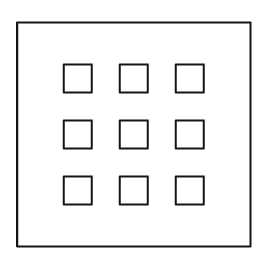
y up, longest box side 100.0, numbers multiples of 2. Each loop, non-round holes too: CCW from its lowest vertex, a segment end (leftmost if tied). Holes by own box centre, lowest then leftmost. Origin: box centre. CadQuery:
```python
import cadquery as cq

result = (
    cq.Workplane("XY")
    .moveTo(-50.0, -48.0)
    .lineTo(50.0, -48.0)
    .lineTo(50.0, 48.0)
    .lineTo(-50.0, 48.0)
    .close()
    .moveTo(-30.0, -30.0)
    .lineTo(-18.0, -30.0)
    .lineTo(-18.0, -18.0)
    .lineTo(-30.0, -18.0)
    .close()
    .moveTo(-6.0, -30.0)
    .lineTo(6.0, -30.0)
    .lineTo(6.0, -18.0)
    .lineTo(-6.0, -18.0)
    .close()
    .moveTo(18.0, -30.0)
    .lineTo(30.0, -30.0)
    .lineTo(30.0, -18.0)
    .lineTo(18.0, -18.0)
    .close()
    .moveTo(-30.0, -6.0)
    .lineTo(-18.0, -6.0)
    .lineTo(-18.0, 6.0)
    .lineTo(-30.0, 6.0)
    .close()
    .moveTo(-6.0, -6.0)
    .lineTo(6.0, -6.0)
    .lineTo(6.0, 6.0)
    .lineTo(-6.0, 6.0)
    .close()
    .moveTo(18.0, -6.0)
    .lineTo(30.0, -6.0)
    .lineTo(30.0, 6.0)
    .lineTo(18.0, 6.0)
    .close()
    .moveTo(-30.0, 18.0)
    .lineTo(-18.0, 18.0)
    .lineTo(-18.0, 30.0)
    .lineTo(-30.0, 30.0)
    .close()
    .moveTo(-6.0, 18.0)
    .lineTo(6.0, 18.0)
    .lineTo(6.0, 30.0)
    .lineTo(-6.0, 30.0)
    .close()
    .moveTo(18.0, 18.0)
    .lineTo(30.0, 18.0)
    .lineTo(30.0, 30.0)
    .lineTo(18.0, 30.0)
    .close()
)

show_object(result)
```